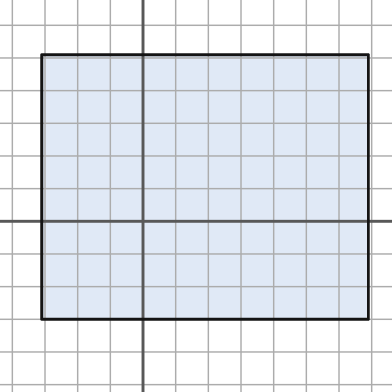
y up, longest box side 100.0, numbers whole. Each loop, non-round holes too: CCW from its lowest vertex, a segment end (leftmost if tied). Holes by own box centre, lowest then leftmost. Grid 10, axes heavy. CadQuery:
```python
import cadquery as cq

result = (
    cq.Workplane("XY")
    .moveTo(-31.0, -30.0)
    .lineTo(69.0, -30.0)
    .lineTo(69.0, 51.0)
    .lineTo(-31.0, 51.0)
    .close()
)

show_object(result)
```